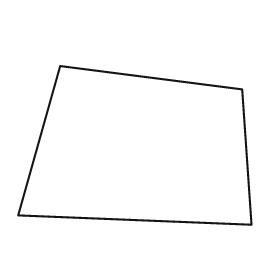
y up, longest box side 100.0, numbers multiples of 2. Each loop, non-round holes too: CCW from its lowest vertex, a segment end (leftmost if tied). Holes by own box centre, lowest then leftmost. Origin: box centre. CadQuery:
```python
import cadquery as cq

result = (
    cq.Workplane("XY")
    .moveTo(50.0, -34.0)
    .lineTo(46.0, 24.0)
    .lineTo(-32.0, 34.0)
    .lineTo(-50.0, -30.0)
    .close()
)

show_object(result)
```